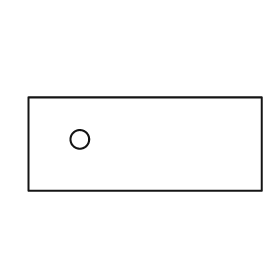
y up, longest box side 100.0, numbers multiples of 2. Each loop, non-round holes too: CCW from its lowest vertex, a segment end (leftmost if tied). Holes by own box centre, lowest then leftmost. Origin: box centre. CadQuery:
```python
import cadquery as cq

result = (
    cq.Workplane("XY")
    .moveTo(-50.0, -20.0)
    .lineTo(50.0, -20.0)
    .lineTo(50.0, 20.0)
    .lineTo(-50.0, 20.0)
    .close()
    .moveTo(-28.0, 2.0)
    .circle(4.0)
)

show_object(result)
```